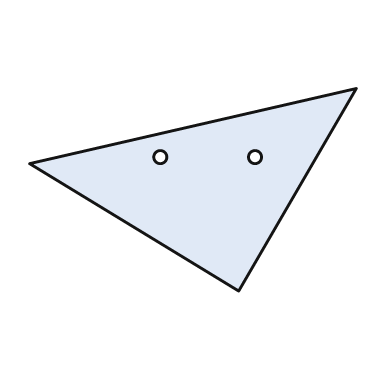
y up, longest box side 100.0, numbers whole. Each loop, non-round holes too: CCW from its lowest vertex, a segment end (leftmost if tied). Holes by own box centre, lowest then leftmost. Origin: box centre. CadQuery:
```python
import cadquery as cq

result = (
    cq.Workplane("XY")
    .moveTo(14.0, -31.0)
    .lineTo(50.0, 31.0)
    .lineTo(-50.0, 8.0)
    .close()
    .moveTo(-10.0, 10.0)
    .circle(2.0)
    .moveTo(19.0, 10.0)
    .circle(2.0)
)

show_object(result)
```